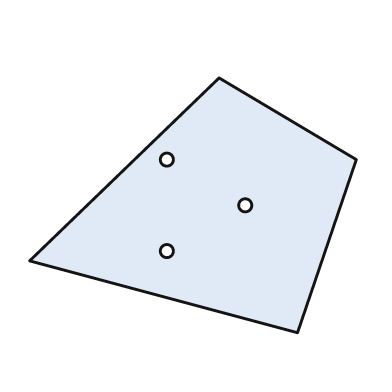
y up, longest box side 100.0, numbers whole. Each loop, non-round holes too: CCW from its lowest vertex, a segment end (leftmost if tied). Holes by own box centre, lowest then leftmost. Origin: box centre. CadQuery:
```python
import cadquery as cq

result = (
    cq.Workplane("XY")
    .moveTo(32.0, -39.0)
    .lineTo(50.0, 14.0)
    .lineTo(8.0, 39.0)
    .lineTo(-50.0, -17.0)
    .close()
    .moveTo(-8.0, -14.0)
    .circle(2.0)
    .moveTo(16.0, 0.0)
    .circle(2.0)
    .moveTo(-8.0, 14.0)
    .circle(2.0)
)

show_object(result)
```